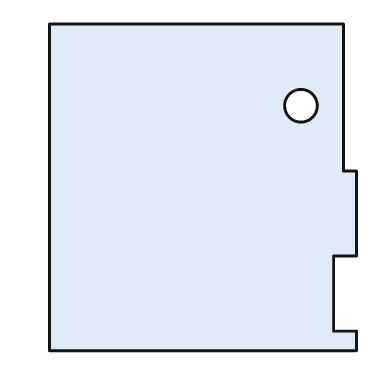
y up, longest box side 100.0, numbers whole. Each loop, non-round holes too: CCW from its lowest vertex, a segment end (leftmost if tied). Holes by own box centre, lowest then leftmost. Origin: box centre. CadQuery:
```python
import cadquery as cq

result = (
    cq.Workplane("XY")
    .moveTo(-47.0, -50.0)
    .lineTo(47.0, -50.0)
    .lineTo(47.0, -44.0)
    .lineTo(40.0, -44.0)
    .lineTo(40.0, -21.0)
    .lineTo(47.0, -21.0)
    .lineTo(47.0, 5.0)
    .lineTo(43.0, 5.0)
    .lineTo(43.0, 50.0)
    .lineTo(-47.0, 50.0)
    .close()
    .moveTo(30.0, 25.0)
    .circle(5.0)
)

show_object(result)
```